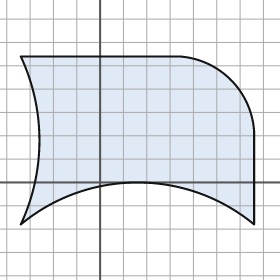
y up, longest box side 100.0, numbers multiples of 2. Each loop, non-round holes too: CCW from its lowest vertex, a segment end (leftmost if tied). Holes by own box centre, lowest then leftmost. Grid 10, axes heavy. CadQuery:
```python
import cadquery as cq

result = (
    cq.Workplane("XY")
    .moveTo(-34.0, -18.0)
    .threePointArc((16.0, 0.0), (66.0, -18.0))
    .lineTo(66.0, 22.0)
    .threePointArc((56.0, 44.0), (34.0, 54.0))
    .lineTo(-34.0, 54.0)
    .threePointArc((-26.0, 18.0), (-34.0, -18.0))
    .close()
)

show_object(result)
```